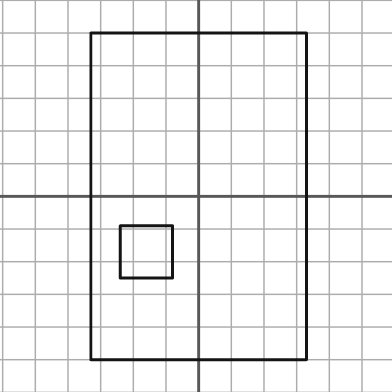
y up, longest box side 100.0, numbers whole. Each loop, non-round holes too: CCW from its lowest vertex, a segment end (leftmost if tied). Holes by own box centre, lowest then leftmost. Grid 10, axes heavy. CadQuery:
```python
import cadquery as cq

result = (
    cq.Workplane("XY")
    .moveTo(-33.0, -50.0)
    .lineTo(33.0, -50.0)
    .lineTo(33.0, 50.0)
    .lineTo(-33.0, 50.0)
    .close()
    .moveTo(-24.0, -25.0)
    .lineTo(-8.0, -25.0)
    .lineTo(-8.0, -9.0)
    .lineTo(-24.0, -9.0)
    .close()
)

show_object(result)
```